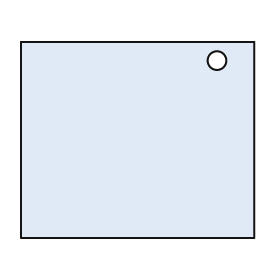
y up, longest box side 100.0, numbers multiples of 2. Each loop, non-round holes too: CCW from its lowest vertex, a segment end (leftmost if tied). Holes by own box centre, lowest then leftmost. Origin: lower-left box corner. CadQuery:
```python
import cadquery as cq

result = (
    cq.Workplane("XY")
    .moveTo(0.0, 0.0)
    .lineTo(100.0, 0.0)
    .lineTo(100.0, 84.0)
    .lineTo(0.0, 84.0)
    .close()
    .moveTo(84.0, 76.0)
    .circle(4.0)
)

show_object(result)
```